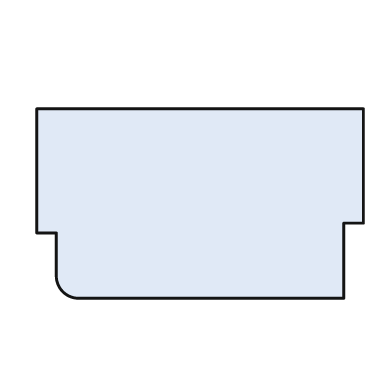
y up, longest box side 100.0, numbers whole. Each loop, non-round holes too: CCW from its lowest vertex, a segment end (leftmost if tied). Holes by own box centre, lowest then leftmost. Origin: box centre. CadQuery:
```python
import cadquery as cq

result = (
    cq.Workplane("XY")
    .moveTo(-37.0, -29.0)
    .lineTo(44.0, -29.0)
    .lineTo(44.0, -6.0)
    .lineTo(50.0, -6.0)
    .lineTo(50.0, 29.0)
    .lineTo(-50.0, 29.0)
    .lineTo(-50.0, -9.0)
    .lineTo(-44.0, -9.0)
    .lineTo(-44.0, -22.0)
    .threePointArc((-42.0, -27.0), (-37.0, -29.0))
    .close()
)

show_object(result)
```